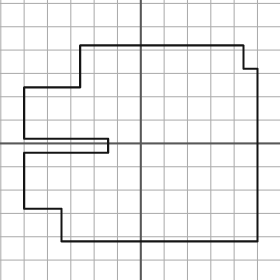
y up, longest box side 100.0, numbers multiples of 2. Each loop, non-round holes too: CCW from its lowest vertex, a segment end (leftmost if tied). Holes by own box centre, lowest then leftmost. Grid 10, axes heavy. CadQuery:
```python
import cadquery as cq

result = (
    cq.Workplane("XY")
    .moveTo(-34.0, -42.0)
    .lineTo(50.0, -42.0)
    .lineTo(50.0, 32.0)
    .lineTo(44.0, 32.0)
    .lineTo(44.0, 42.0)
    .lineTo(-26.0, 42.0)
    .lineTo(-26.0, 24.0)
    .lineTo(-50.0, 24.0)
    .lineTo(-50.0, 2.0)
    .lineTo(-14.0, 2.0)
    .lineTo(-14.0, -4.0)
    .lineTo(-50.0, -4.0)
    .lineTo(-50.0, -28.0)
    .lineTo(-34.0, -28.0)
    .close()
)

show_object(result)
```